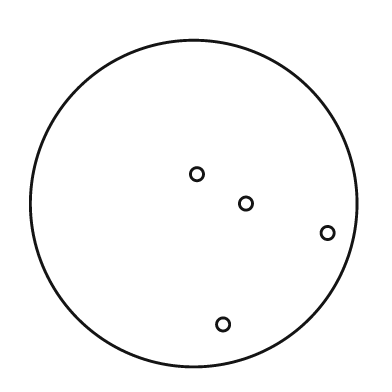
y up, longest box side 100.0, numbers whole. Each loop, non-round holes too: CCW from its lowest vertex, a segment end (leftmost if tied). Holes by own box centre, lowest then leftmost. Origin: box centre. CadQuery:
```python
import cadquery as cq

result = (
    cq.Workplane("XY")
    .moveTo(0.0, 0.0)
    .circle(50.0)
    .moveTo(9.0, -37.0)
    .circle(2.0)
    .moveTo(41.0, -9.0)
    .circle(2.0)
    .moveTo(16.0, 0.0)
    .circle(2.0)
    .moveTo(1.0, 9.0)
    .circle(2.0)
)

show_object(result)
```